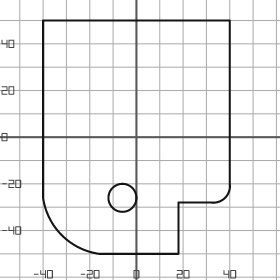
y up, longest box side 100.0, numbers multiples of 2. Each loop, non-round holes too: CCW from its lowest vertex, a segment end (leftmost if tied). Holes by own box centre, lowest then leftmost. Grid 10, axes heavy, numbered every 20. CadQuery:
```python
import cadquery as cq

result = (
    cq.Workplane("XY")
    .moveTo(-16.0, -50.0)
    .lineTo(18.0, -50.0)
    .lineTo(18.0, -28.0)
    .lineTo(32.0, -28.0)
    .threePointArc((38.0, -26.0), (40.0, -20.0))
    .lineTo(40.0, 50.0)
    .lineTo(-40.0, 50.0)
    .lineTo(-40.0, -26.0)
    .threePointArc((-32.0, -42.0), (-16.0, -50.0))
    .close()
    .moveTo(-6.0, -26.0)
    .circle(6.0)
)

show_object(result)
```